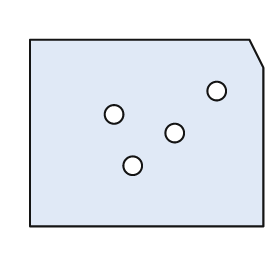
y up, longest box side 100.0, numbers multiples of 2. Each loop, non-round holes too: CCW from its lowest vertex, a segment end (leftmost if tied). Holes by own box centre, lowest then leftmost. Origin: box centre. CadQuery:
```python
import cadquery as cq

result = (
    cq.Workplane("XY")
    .moveTo(-50.0, -40.0)
    .lineTo(50.0, -40.0)
    .lineTo(50.0, 28.0)
    .lineTo(44.0, 40.0)
    .lineTo(-50.0, 40.0)
    .close()
    .moveTo(-6.0, -14.0)
    .circle(4.0)
    .moveTo(12.0, 0.0)
    .circle(4.0)
    .moveTo(-14.0, 8.0)
    .circle(4.0)
    .moveTo(30.0, 18.0)
    .circle(4.0)
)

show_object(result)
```